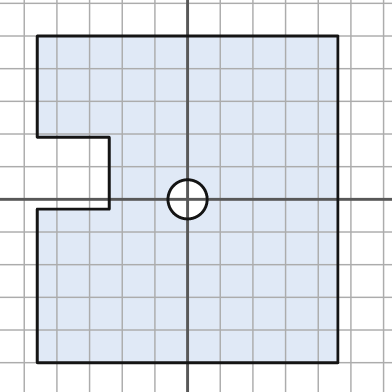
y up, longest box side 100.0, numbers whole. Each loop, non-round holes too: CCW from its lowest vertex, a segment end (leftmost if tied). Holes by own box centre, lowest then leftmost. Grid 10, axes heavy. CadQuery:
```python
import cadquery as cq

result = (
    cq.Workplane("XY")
    .moveTo(-46.0, -50.0)
    .lineTo(46.0, -50.0)
    .lineTo(46.0, 50.0)
    .lineTo(-46.0, 50.0)
    .lineTo(-46.0, 19.0)
    .lineTo(-24.0, 19.0)
    .lineTo(-24.0, -3.0)
    .lineTo(-46.0, -3.0)
    .close()
    .moveTo(0.0, 0.0)
    .circle(6.0)
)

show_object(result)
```